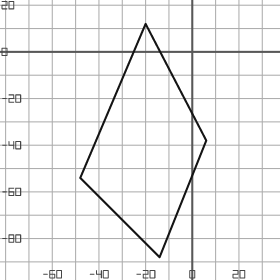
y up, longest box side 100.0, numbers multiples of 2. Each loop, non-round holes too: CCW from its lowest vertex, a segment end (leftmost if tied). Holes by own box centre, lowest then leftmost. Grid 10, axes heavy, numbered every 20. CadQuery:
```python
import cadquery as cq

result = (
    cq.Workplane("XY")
    .moveTo(-14.0, -88.0)
    .lineTo(6.0, -38.0)
    .lineTo(-20.0, 12.0)
    .lineTo(-48.0, -54.0)
    .close()
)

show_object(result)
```